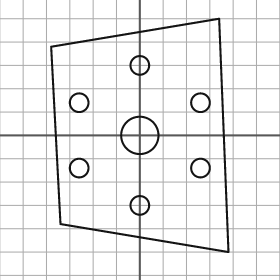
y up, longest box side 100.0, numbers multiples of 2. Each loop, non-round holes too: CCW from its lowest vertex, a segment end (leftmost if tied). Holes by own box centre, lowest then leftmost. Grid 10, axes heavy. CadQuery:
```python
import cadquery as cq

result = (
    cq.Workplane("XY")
    .moveTo(38.0, -50.0)
    .lineTo(34.0, 50.0)
    .lineTo(-38.0, 38.0)
    .lineTo(-34.0, -38.0)
    .close()
    .moveTo(0.0, -30.0)
    .circle(4.0)
    .moveTo(-26.0, -14.0)
    .circle(4.0)
    .moveTo(26.0, -14.0)
    .circle(4.0)
    .moveTo(0.0, 0.0)
    .circle(8.0)
    .moveTo(-26.0, 14.0)
    .circle(4.0)
    .moveTo(26.0, 14.0)
    .circle(4.0)
    .moveTo(0.0, 30.0)
    .circle(4.0)
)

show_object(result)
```